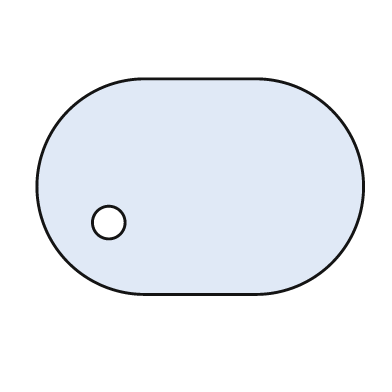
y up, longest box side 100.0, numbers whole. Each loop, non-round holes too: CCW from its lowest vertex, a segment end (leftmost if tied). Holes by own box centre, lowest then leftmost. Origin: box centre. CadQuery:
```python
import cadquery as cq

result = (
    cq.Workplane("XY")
    .moveTo(-17.0, -33.0)
    .lineTo(17.0, -33.0)
    .threePointArc((50.0, 0.0), (17.0, 33.0))
    .lineTo(-17.0, 33.0)
    .threePointArc((-50.0, 0.0), (-17.0, -33.0))
    .close()
    .moveTo(-28.0, -11.0)
    .circle(5.0)
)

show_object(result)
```